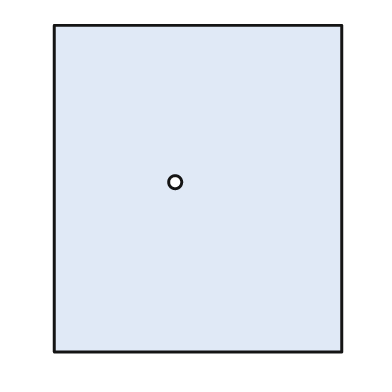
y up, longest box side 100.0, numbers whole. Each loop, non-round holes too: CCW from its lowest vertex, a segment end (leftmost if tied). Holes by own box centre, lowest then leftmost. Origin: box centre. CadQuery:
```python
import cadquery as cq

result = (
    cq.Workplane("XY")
    .moveTo(-44.0, -50.0)
    .lineTo(44.0, -50.0)
    .lineTo(44.0, 50.0)
    .lineTo(-44.0, 50.0)
    .close()
    .moveTo(-7.0, 2.0)
    .circle(2.0)
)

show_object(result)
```